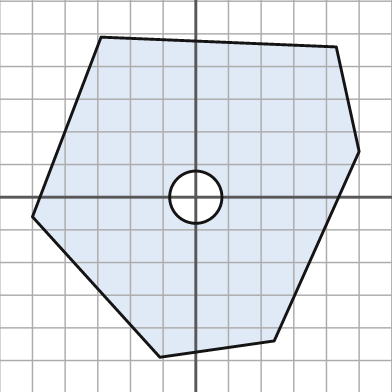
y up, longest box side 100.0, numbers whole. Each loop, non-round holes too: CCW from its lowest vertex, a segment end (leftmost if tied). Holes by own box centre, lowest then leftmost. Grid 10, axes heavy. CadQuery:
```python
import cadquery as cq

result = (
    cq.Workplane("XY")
    .moveTo(-11.0, -49.0)
    .lineTo(24.0, -44.0)
    .lineTo(50.0, 14.0)
    .lineTo(43.0, 46.0)
    .lineTo(-29.0, 49.0)
    .lineTo(-50.0, -6.0)
    .close()
    .moveTo(0.0, 0.0)
    .circle(8.0)
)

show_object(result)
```